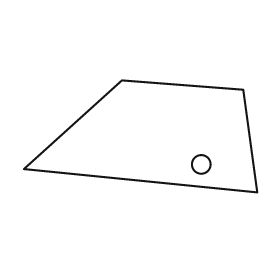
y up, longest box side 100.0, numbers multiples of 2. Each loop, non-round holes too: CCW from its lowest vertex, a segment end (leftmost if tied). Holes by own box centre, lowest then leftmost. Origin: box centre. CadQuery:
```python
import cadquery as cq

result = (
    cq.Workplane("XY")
    .moveTo(50.0, -24.0)
    .lineTo(44.0, 20.0)
    .lineTo(-8.0, 24.0)
    .lineTo(-50.0, -14.0)
    .close()
    .moveTo(26.0, -12.0)
    .circle(4.0)
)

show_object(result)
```